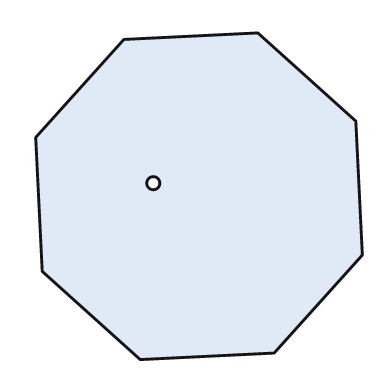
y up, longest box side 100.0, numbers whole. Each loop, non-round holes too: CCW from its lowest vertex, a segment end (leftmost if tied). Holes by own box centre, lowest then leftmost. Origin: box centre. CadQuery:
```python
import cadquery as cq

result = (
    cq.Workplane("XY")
    .moveTo(-18.0, -50.0)
    .lineTo(23.0, -48.0)
    .lineTo(50.0, -18.0)
    .lineTo(48.0, 23.0)
    .lineTo(18.0, 50.0)
    .lineTo(-23.0, 48.0)
    .lineTo(-50.0, 18.0)
    .lineTo(-48.0, -23.0)
    .close()
    .moveTo(-14.0, 4.0)
    .circle(2.0)
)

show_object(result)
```